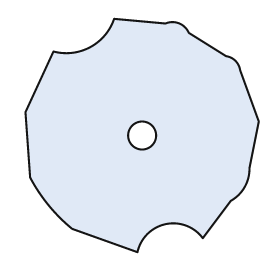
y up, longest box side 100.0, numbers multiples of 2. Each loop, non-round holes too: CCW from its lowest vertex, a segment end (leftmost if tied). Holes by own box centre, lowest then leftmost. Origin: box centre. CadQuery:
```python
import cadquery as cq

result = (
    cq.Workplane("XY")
    .moveTo(-2.0, -50.0)
    .threePointArc((10.0, -38.0), (26.0, -44.0))
    .lineTo(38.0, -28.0)
    .threePointArc((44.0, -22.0), (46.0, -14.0))
    .lineTo(50.0, 6.0)
    .lineTo(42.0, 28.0)
    .threePointArc((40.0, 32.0), (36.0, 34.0))
    .lineTo(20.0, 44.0)
    .threePointArc((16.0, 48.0), (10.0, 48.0))
    .lineTo(-12.0, 50.0)
    .threePointArc((-22.0, 38.0), (-38.0, 36.0))
    .lineTo(-50.0, 10.0)
    .lineTo(-48.0, -18.0)
    .threePointArc((-40.0, -30.0), (-30.0, -40.0))
    .close()
    .moveTo(0.0, 0.0)
    .circle(6.0)
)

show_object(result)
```